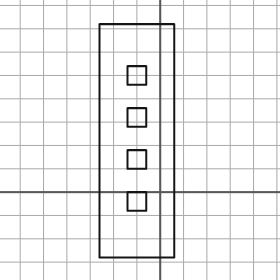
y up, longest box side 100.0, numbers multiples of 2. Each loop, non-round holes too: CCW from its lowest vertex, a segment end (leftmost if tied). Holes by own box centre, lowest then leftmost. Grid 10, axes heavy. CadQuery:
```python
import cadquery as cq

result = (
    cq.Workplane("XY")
    .moveTo(-26.0, -28.0)
    .lineTo(6.0, -28.0)
    .lineTo(6.0, 72.0)
    .lineTo(-26.0, 72.0)
    .close()
    .moveTo(-14.0, -8.0)
    .lineTo(-6.0, -8.0)
    .lineTo(-6.0, 0.0)
    .lineTo(-14.0, 0.0)
    .close()
    .moveTo(-14.0, 10.0)
    .lineTo(-6.0, 10.0)
    .lineTo(-6.0, 18.0)
    .lineTo(-14.0, 18.0)
    .close()
    .moveTo(-14.0, 28.0)
    .lineTo(-6.0, 28.0)
    .lineTo(-6.0, 36.0)
    .lineTo(-14.0, 36.0)
    .close()
    .moveTo(-14.0, 46.0)
    .lineTo(-6.0, 46.0)
    .lineTo(-6.0, 54.0)
    .lineTo(-14.0, 54.0)
    .close()
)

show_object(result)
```